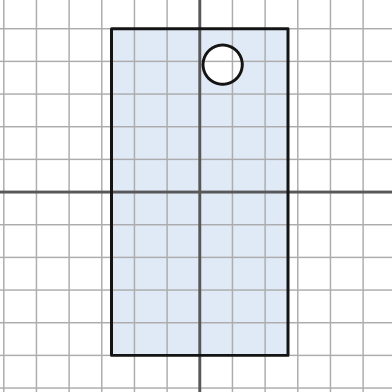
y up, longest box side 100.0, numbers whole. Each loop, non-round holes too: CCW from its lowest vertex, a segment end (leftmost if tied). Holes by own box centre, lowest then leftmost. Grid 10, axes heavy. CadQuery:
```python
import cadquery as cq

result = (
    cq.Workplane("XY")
    .moveTo(-27.0, -50.0)
    .lineTo(27.0, -50.0)
    .lineTo(27.0, 50.0)
    .lineTo(-27.0, 50.0)
    .close()
    .moveTo(7.0, 39.0)
    .circle(6.0)
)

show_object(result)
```